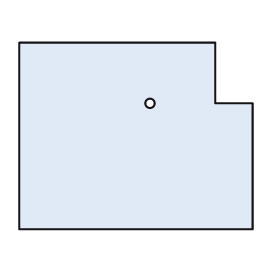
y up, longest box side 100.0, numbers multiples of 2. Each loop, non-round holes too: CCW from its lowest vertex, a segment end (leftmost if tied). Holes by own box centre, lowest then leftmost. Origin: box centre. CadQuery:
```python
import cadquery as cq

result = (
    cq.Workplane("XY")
    .moveTo(-50.0, -40.0)
    .lineTo(50.0, -40.0)
    .lineTo(50.0, 14.0)
    .lineTo(34.0, 14.0)
    .lineTo(34.0, 40.0)
    .lineTo(-50.0, 40.0)
    .close()
    .moveTo(6.0, 14.0)
    .circle(2.0)
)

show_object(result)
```